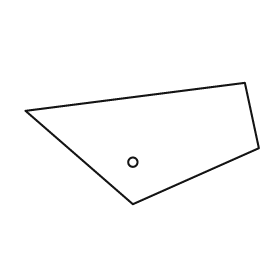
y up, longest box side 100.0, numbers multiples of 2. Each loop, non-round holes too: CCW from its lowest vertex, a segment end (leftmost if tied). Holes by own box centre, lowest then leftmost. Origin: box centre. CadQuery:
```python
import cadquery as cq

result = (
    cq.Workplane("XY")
    .moveTo(-4.0, -26.0)
    .lineTo(50.0, -2.0)
    .lineTo(44.0, 26.0)
    .lineTo(-50.0, 14.0)
    .close()
    .moveTo(-4.0, -8.0)
    .circle(2.0)
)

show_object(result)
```